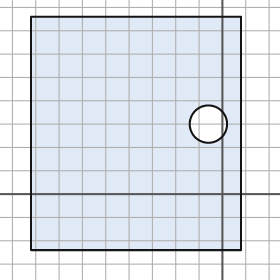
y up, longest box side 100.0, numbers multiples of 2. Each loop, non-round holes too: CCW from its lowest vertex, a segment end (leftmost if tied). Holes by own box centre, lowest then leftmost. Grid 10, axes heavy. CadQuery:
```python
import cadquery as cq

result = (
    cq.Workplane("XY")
    .moveTo(-82.0, -24.0)
    .lineTo(8.0, -24.0)
    .lineTo(8.0, 76.0)
    .lineTo(-82.0, 76.0)
    .close()
    .moveTo(-6.0, 30.0)
    .circle(8.0)
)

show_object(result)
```